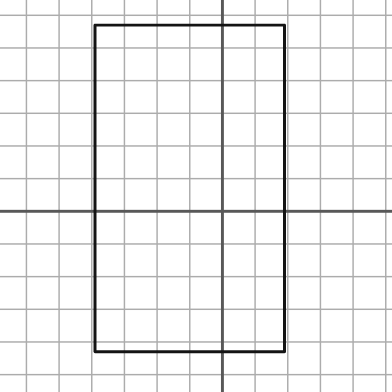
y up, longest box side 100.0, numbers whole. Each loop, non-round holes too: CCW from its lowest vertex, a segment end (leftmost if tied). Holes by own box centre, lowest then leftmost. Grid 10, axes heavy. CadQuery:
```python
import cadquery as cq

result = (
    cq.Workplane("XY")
    .moveTo(-39.0, -43.0)
    .lineTo(19.0, -43.0)
    .lineTo(19.0, 57.0)
    .lineTo(-39.0, 57.0)
    .close()
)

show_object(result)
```